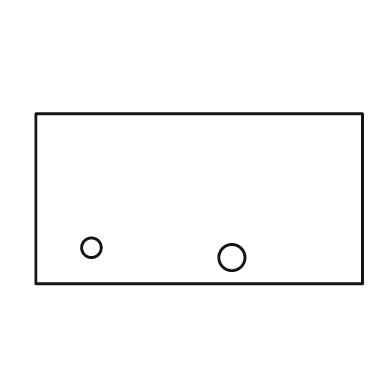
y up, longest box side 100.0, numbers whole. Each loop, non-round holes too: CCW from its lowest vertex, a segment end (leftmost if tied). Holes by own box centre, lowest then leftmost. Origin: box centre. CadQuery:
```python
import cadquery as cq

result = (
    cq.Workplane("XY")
    .moveTo(-50.0, -26.0)
    .lineTo(50.0, -26.0)
    .lineTo(50.0, 26.0)
    .lineTo(-50.0, 26.0)
    .close()
    .moveTo(10.0, -18.0)
    .circle(4.0)
    .moveTo(-33.0, -15.0)
    .circle(3.0)
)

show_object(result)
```